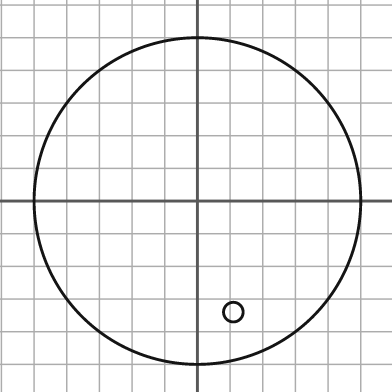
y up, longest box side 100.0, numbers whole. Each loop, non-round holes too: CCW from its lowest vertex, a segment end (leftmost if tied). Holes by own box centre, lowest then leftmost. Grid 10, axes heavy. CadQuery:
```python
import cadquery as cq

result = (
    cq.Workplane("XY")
    .moveTo(0.0, 0.0)
    .circle(50.0)
    .moveTo(11.0, -34.0)
    .circle(3.0)
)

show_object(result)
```